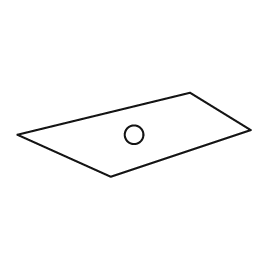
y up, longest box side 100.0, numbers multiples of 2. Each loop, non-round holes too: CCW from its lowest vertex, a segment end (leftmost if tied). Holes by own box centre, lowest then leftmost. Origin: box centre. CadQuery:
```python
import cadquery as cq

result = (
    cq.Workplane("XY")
    .moveTo(-10.0, -18.0)
    .lineTo(50.0, 2.0)
    .lineTo(24.0, 18.0)
    .lineTo(-50.0, 0.0)
    .close()
    .moveTo(0.0, 0.0)
    .circle(4.0)
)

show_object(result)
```